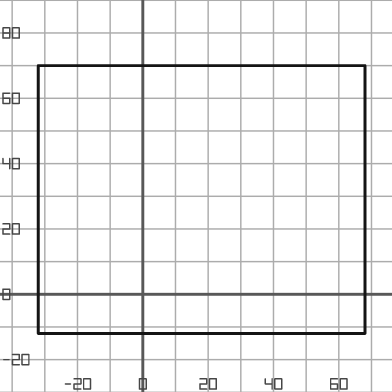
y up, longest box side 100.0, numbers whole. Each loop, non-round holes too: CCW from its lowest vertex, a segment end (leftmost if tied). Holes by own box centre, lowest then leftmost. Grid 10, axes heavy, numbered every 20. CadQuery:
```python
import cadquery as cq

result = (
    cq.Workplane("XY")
    .moveTo(-32.0, -12.0)
    .lineTo(68.0, -12.0)
    .lineTo(68.0, 70.0)
    .lineTo(-32.0, 70.0)
    .close()
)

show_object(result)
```